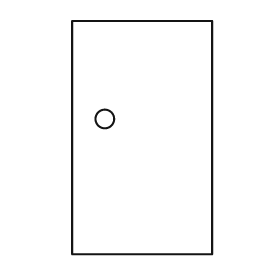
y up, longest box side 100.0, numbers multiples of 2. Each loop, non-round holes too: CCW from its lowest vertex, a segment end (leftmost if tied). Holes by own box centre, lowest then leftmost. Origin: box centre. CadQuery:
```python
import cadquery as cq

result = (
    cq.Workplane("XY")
    .moveTo(-30.0, -50.0)
    .lineTo(30.0, -50.0)
    .lineTo(30.0, 50.0)
    .lineTo(-30.0, 50.0)
    .close()
    .moveTo(-16.0, 8.0)
    .circle(4.0)
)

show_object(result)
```